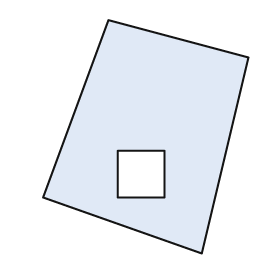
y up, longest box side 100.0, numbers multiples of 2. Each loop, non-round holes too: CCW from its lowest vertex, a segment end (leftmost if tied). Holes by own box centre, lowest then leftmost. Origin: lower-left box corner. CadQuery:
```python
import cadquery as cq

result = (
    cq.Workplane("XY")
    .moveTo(68.0, 0.0)
    .lineTo(88.0, 84.0)
    .lineTo(28.0, 100.0)
    .lineTo(0.0, 24.0)
    .close()
    .moveTo(32.0, 24.0)
    .lineTo(52.0, 24.0)
    .lineTo(52.0, 44.0)
    .lineTo(32.0, 44.0)
    .close()
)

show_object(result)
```